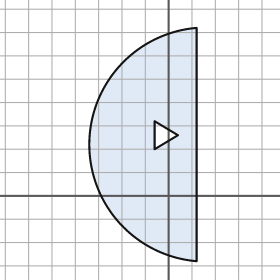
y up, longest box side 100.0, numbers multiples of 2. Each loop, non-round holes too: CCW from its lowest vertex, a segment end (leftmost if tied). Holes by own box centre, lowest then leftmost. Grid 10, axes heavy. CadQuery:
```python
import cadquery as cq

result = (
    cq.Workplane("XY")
    .moveTo(12.0, -28.0)
    .lineTo(12.0, 72.0)
    .threePointArc((-34.0, 22.0), (12.0, -28.0))
    .close()
    .moveTo(-6.0, 20.0)
    .lineTo(4.0, 26.0)
    .lineTo(-6.0, 32.0)
    .close()
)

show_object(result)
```